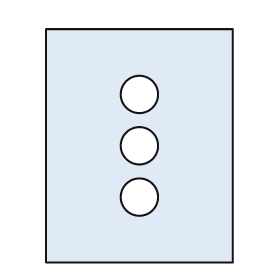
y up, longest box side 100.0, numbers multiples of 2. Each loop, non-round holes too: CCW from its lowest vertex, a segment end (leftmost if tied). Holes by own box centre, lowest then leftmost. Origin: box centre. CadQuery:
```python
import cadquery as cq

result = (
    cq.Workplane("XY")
    .moveTo(-40.0, -50.0)
    .lineTo(40.0, -50.0)
    .lineTo(40.0, 50.0)
    .lineTo(-40.0, 50.0)
    .close()
    .moveTo(0.0, -22.0)
    .circle(8.0)
    .moveTo(0.0, 0.0)
    .circle(8.0)
    .moveTo(0.0, 22.0)
    .circle(8.0)
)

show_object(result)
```